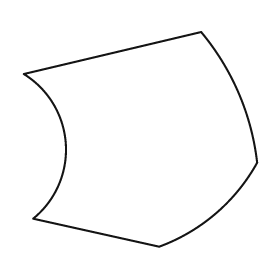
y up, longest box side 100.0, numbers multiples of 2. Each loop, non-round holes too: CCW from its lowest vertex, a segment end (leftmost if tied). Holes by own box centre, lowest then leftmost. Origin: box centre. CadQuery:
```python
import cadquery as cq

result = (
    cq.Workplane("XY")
    .moveTo(8.0, -46.0)
    .threePointArc((32.0, -32.0), (50.0, -10.0))
    .threePointArc((42.0, 20.0), (26.0, 46.0))
    .lineTo(-50.0, 28.0)
    .threePointArc((-32.0, -2.0), (-46.0, -34.0))
    .close()
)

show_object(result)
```